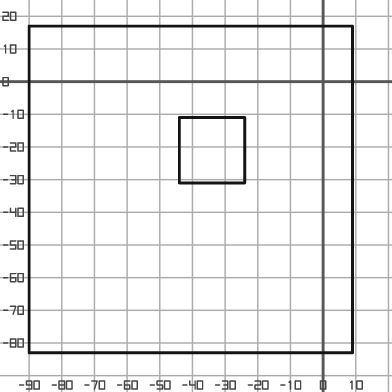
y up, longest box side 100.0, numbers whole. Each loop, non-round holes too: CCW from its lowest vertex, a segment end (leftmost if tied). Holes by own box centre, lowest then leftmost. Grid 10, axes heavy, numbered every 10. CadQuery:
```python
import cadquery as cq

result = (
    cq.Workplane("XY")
    .moveTo(-90.0, -83.0)
    .lineTo(9.0, -83.0)
    .lineTo(9.0, 17.0)
    .lineTo(-90.0, 17.0)
    .close()
    .moveTo(-44.0, -31.0)
    .lineTo(-24.0, -31.0)
    .lineTo(-24.0, -11.0)
    .lineTo(-44.0, -11.0)
    .close()
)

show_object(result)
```